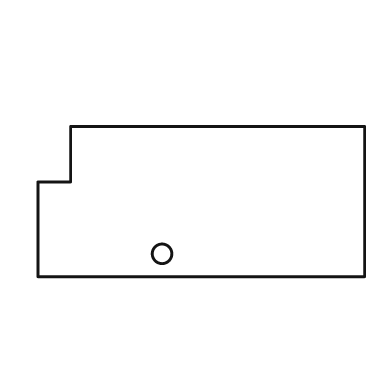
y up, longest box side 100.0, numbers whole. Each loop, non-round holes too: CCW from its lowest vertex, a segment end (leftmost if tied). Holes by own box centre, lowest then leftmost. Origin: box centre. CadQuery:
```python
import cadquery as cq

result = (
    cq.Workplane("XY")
    .moveTo(-50.0, -23.0)
    .lineTo(50.0, -23.0)
    .lineTo(50.0, 23.0)
    .lineTo(-40.0, 23.0)
    .lineTo(-40.0, 6.0)
    .lineTo(-50.0, 6.0)
    .close()
    .moveTo(-12.0, -16.0)
    .circle(3.0)
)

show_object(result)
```